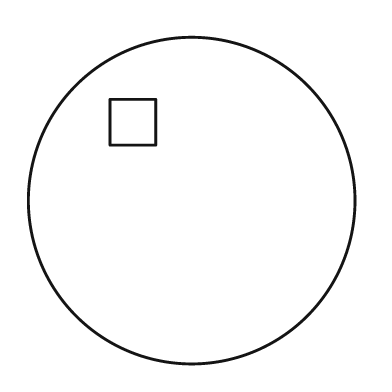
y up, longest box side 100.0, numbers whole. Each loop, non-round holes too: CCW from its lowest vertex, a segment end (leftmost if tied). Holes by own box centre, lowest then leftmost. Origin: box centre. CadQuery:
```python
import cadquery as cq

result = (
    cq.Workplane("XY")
    .moveTo(0.0, 0.0)
    .circle(50.0)
    .moveTo(-25.0, 17.0)
    .lineTo(-11.0, 17.0)
    .lineTo(-11.0, 31.0)
    .lineTo(-25.0, 31.0)
    .close()
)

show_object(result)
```